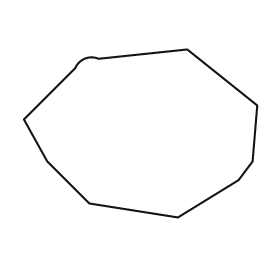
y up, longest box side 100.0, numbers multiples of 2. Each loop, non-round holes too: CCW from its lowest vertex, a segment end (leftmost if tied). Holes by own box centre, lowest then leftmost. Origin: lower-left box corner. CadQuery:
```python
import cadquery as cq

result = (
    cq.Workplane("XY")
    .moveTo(66.0, 0.0)
    .lineTo(92.0, 16.0)
    .lineTo(98.0, 24.0)
    .lineTo(100.0, 48.0)
    .lineTo(70.0, 72.0)
    .lineTo(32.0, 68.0)
    .threePointArc((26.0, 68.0), (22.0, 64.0))
    .lineTo(0.0, 42.0)
    .lineTo(10.0, 24.0)
    .lineTo(28.0, 6.0)
    .close()
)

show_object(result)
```